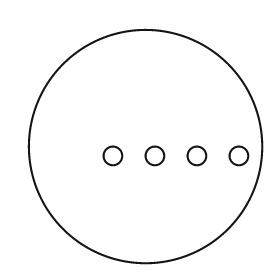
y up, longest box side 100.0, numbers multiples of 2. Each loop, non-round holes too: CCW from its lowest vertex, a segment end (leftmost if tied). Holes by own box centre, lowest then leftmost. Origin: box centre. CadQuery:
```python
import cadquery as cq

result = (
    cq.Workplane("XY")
    .moveTo(0.0, 0.0)
    .circle(50.0)
    .moveTo(-14.0, -4.0)
    .circle(4.0)
    .moveTo(4.0, -4.0)
    .circle(4.0)
    .moveTo(22.0, -4.0)
    .circle(4.0)
    .moveTo(40.0, -4.0)
    .circle(4.0)
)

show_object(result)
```